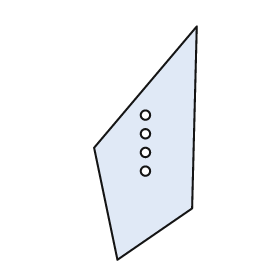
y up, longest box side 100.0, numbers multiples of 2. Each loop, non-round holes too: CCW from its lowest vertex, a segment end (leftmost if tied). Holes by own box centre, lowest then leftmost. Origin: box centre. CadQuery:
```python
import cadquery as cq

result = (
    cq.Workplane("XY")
    .moveTo(-12.0, -50.0)
    .lineTo(20.0, -28.0)
    .lineTo(22.0, 50.0)
    .lineTo(-22.0, -2.0)
    .close()
    .moveTo(0.0, -12.0)
    .circle(2.0)
    .moveTo(0.0, -4.0)
    .circle(2.0)
    .moveTo(0.0, 4.0)
    .circle(2.0)
    .moveTo(0.0, 12.0)
    .circle(2.0)
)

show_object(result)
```